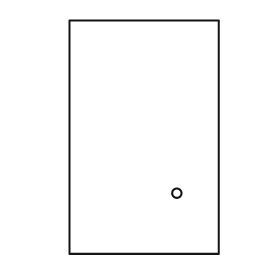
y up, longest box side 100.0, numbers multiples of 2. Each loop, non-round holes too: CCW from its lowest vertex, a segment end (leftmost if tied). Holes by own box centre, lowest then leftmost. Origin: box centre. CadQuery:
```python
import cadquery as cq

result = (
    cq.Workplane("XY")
    .moveTo(-32.0, -50.0)
    .lineTo(32.0, -50.0)
    .lineTo(32.0, 50.0)
    .lineTo(-32.0, 50.0)
    .close()
    .moveTo(14.0, -24.0)
    .circle(2.0)
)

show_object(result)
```